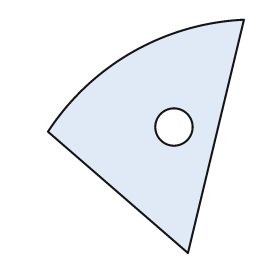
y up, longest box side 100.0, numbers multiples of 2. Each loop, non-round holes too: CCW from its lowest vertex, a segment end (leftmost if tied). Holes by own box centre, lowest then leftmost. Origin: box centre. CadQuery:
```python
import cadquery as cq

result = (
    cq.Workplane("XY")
    .moveTo(18.0, -50.0)
    .lineTo(42.0, 50.0)
    .threePointArc((-6.0, 36.0), (-42.0, 2.0))
    .close()
    .moveTo(12.0, 4.0)
    .circle(8.0)
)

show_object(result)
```